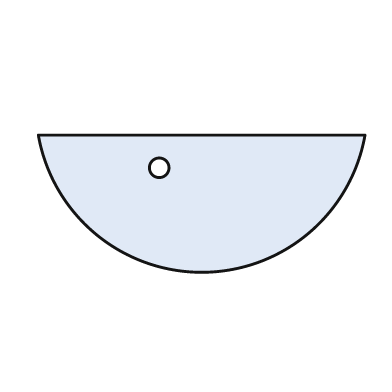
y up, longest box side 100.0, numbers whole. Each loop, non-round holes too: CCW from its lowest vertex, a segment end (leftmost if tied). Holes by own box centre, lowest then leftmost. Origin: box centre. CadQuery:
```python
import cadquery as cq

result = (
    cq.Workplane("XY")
    .moveTo(-50.0, 21.0)
    .threePointArc((0.0, -21.0), (50.0, 21.0))
    .close()
    .moveTo(-13.0, 11.0)
    .circle(3.0)
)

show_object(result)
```